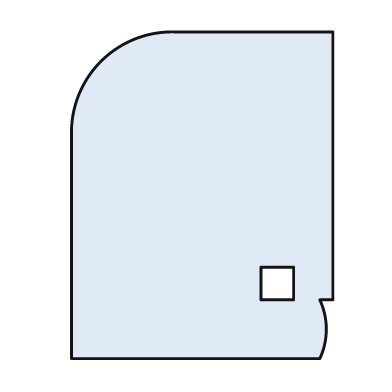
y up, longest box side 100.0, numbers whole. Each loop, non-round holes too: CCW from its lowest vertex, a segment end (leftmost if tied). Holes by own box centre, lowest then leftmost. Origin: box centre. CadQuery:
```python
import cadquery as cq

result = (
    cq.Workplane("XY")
    .moveTo(-40.0, -50.0)
    .lineTo(36.0, -50.0)
    .threePointArc((38.0, -41.0), (36.0, -32.0))
    .lineTo(40.0, -32.0)
    .lineTo(40.0, 50.0)
    .lineTo(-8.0, 50.0)
    .threePointArc((-31.0, 41.0), (-40.0, 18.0))
    .close()
    .moveTo(18.0, -32.0)
    .lineTo(28.0, -32.0)
    .lineTo(28.0, -22.0)
    .lineTo(18.0, -22.0)
    .close()
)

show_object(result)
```